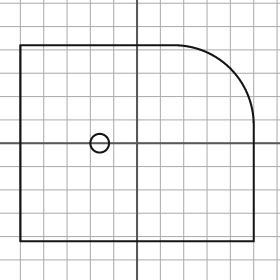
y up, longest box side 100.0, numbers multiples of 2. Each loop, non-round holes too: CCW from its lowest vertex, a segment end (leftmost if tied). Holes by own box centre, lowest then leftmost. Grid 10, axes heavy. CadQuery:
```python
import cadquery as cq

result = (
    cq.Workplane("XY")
    .moveTo(-50.0, -42.0)
    .lineTo(50.0, -42.0)
    .lineTo(50.0, 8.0)
    .threePointArc((40.0, 32.0), (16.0, 42.0))
    .lineTo(-50.0, 42.0)
    .close()
    .moveTo(-16.0, 0.0)
    .circle(4.0)
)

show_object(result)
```